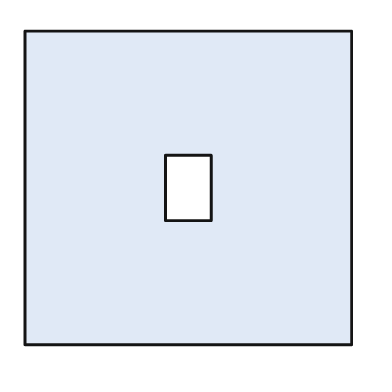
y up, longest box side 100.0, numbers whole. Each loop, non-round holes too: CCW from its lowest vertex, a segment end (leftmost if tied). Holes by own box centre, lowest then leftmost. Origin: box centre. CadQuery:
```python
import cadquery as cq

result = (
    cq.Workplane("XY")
    .moveTo(-50.0, -48.0)
    .lineTo(50.0, -48.0)
    .lineTo(50.0, 48.0)
    .lineTo(-50.0, 48.0)
    .close()
    .moveTo(-7.0, -10.0)
    .lineTo(7.0, -10.0)
    .lineTo(7.0, 10.0)
    .lineTo(-7.0, 10.0)
    .close()
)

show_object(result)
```